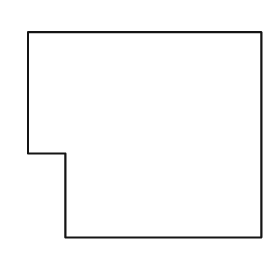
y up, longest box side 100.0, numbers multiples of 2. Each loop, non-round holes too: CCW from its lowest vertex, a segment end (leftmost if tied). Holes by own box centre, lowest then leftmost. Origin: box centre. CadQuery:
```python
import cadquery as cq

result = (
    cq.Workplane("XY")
    .moveTo(-34.0, -44.0)
    .lineTo(50.0, -44.0)
    .lineTo(50.0, 44.0)
    .lineTo(-50.0, 44.0)
    .lineTo(-50.0, -8.0)
    .lineTo(-34.0, -8.0)
    .close()
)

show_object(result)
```